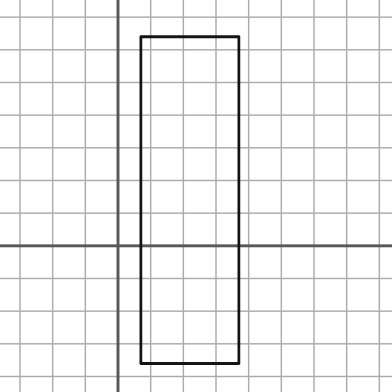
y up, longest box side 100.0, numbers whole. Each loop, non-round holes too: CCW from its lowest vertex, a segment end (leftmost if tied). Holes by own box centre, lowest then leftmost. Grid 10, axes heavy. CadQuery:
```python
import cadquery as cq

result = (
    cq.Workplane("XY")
    .moveTo(7.0, -36.0)
    .lineTo(37.0, -36.0)
    .lineTo(37.0, 64.0)
    .lineTo(7.0, 64.0)
    .close()
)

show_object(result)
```